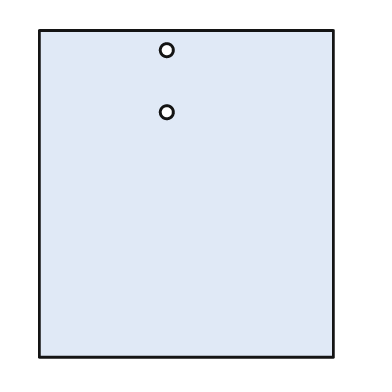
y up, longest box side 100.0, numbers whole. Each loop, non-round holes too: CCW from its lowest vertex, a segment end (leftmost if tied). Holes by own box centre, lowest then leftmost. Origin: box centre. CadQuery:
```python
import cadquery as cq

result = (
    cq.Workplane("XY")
    .moveTo(-45.0, -50.0)
    .lineTo(45.0, -50.0)
    .lineTo(45.0, 50.0)
    .lineTo(-45.0, 50.0)
    .close()
    .moveTo(-6.0, 25.0)
    .circle(2.0)
    .moveTo(-6.0, 44.0)
    .circle(2.0)
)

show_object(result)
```